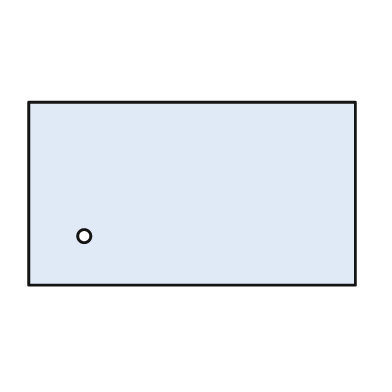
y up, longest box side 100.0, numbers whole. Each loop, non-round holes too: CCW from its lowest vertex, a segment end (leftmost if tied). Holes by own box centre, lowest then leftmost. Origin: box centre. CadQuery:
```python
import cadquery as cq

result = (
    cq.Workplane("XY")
    .moveTo(-50.0, -28.0)
    .lineTo(50.0, -28.0)
    .lineTo(50.0, 28.0)
    .lineTo(-50.0, 28.0)
    .close()
    .moveTo(-33.0, -13.0)
    .circle(2.0)
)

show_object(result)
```